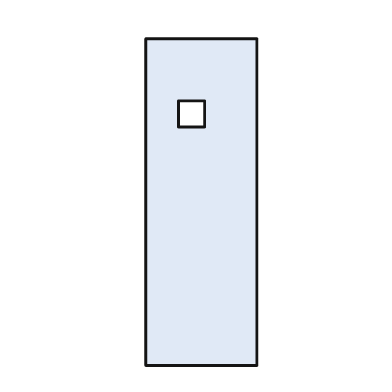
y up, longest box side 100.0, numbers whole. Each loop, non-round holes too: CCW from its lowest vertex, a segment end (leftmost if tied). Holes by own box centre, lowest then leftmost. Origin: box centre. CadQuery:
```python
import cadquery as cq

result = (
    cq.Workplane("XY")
    .moveTo(-17.0, -50.0)
    .lineTo(17.0, -50.0)
    .lineTo(17.0, 50.0)
    .lineTo(-17.0, 50.0)
    .close()
    .moveTo(-7.0, 23.0)
    .lineTo(1.0, 23.0)
    .lineTo(1.0, 31.0)
    .lineTo(-7.0, 31.0)
    .close()
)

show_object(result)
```